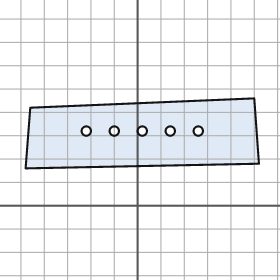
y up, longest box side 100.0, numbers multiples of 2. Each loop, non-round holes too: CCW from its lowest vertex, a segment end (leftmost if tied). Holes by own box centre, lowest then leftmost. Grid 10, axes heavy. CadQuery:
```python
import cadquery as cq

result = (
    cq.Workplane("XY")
    .moveTo(-48.0, 16.0)
    .lineTo(52.0, 18.0)
    .lineTo(50.0, 46.0)
    .lineTo(-46.0, 42.0)
    .close()
    .moveTo(-22.0, 32.0)
    .circle(2.0)
    .moveTo(-10.0, 32.0)
    .circle(2.0)
    .moveTo(2.0, 32.0)
    .circle(2.0)
    .moveTo(14.0, 32.0)
    .circle(2.0)
    .moveTo(26.0, 32.0)
    .circle(2.0)
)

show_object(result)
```